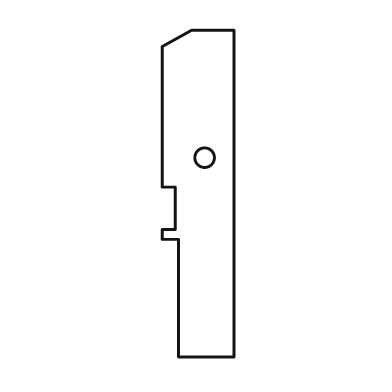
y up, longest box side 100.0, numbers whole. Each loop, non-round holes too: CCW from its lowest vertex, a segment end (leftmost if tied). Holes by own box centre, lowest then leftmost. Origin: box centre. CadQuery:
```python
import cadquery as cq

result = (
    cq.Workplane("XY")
    .moveTo(-6.0, -50.0)
    .lineTo(11.0, -50.0)
    .lineTo(11.0, 50.0)
    .lineTo(-2.0, 50.0)
    .lineTo(-11.0, 45.0)
    .lineTo(-11.0, 2.0)
    .lineTo(-7.0, 2.0)
    .lineTo(-7.0, -11.0)
    .lineTo(-11.0, -11.0)
    .lineTo(-11.0, -14.0)
    .lineTo(-6.0, -14.0)
    .close()
    .moveTo(2.0, 11.0)
    .circle(3.0)
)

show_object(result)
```